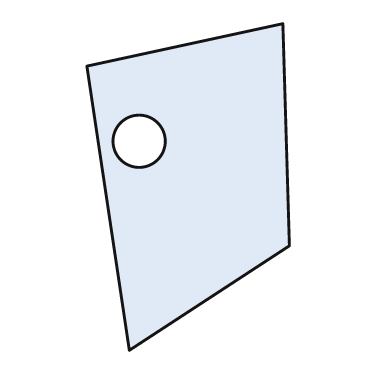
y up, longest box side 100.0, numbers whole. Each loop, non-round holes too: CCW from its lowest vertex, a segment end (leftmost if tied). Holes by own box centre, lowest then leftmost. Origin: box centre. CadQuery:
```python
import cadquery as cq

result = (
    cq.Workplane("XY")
    .moveTo(-18.0, -50.0)
    .lineTo(31.0, -18.0)
    .lineTo(29.0, 50.0)
    .lineTo(-31.0, 37.0)
    .close()
    .moveTo(-15.0, 14.0)
    .circle(8.0)
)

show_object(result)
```